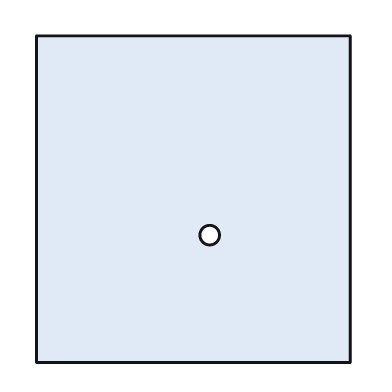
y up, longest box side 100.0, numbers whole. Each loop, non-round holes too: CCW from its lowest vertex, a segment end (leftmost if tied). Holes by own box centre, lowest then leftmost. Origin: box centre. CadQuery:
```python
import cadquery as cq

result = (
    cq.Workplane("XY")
    .moveTo(-48.0, -50.0)
    .lineTo(48.0, -50.0)
    .lineTo(48.0, 50.0)
    .lineTo(-48.0, 50.0)
    .close()
    .moveTo(5.0, -11.0)
    .circle(3.0)
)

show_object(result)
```